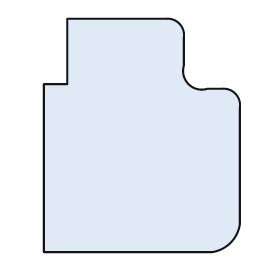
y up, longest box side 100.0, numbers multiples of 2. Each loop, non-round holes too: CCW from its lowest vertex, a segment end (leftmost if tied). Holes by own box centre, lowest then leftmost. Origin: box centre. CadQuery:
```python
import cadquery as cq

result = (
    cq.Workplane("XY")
    .moveTo(-42.0, -50.0)
    .lineTo(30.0, -50.0)
    .threePointArc((38.0, -46.0), (42.0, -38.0))
    .lineTo(42.0, 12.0)
    .threePointArc((40.0, 18.0), (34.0, 20.0))
    .lineTo(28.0, 20.0)
    .threePointArc((20.0, 22.0), (18.0, 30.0))
    .lineTo(18.0, 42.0)
    .threePointArc((16.0, 48.0), (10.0, 50.0))
    .lineTo(-32.0, 50.0)
    .lineTo(-32.0, 22.0)
    .lineTo(-42.0, 22.0)
    .close()
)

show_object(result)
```